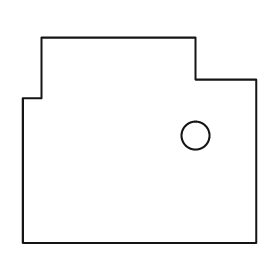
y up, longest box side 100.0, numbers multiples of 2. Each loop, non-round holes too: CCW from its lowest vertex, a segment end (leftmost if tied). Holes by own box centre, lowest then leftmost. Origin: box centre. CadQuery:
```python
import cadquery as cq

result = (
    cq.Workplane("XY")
    .moveTo(-50.0, -44.0)
    .lineTo(50.0, -44.0)
    .lineTo(50.0, 26.0)
    .lineTo(24.0, 26.0)
    .lineTo(24.0, 44.0)
    .lineTo(-42.0, 44.0)
    .lineTo(-42.0, 18.0)
    .lineTo(-50.0, 18.0)
    .close()
    .moveTo(24.0, 2.0)
    .circle(6.0)
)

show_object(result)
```